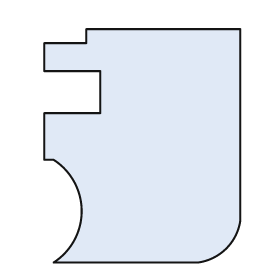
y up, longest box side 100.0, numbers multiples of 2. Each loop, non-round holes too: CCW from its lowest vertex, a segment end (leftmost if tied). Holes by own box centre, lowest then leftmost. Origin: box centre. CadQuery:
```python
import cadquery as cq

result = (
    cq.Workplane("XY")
    .moveTo(-38.0, -50.0)
    .lineTo(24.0, -50.0)
    .threePointArc((36.0, -44.0), (42.0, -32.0))
    .lineTo(42.0, 50.0)
    .lineTo(-24.0, 50.0)
    .lineTo(-24.0, 44.0)
    .lineTo(-42.0, 44.0)
    .lineTo(-42.0, 32.0)
    .lineTo(-18.0, 32.0)
    .lineTo(-18.0, 14.0)
    .lineTo(-42.0, 14.0)
    .lineTo(-42.0, -6.0)
    .lineTo(-38.0, -6.0)
    .threePointArc((-26.0, -28.0), (-38.0, -50.0))
    .close()
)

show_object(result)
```